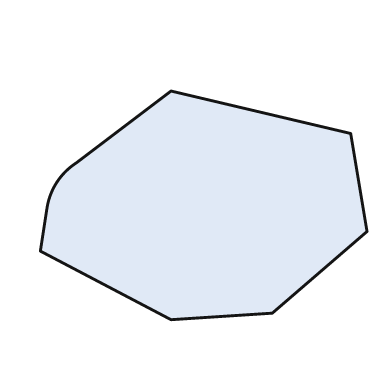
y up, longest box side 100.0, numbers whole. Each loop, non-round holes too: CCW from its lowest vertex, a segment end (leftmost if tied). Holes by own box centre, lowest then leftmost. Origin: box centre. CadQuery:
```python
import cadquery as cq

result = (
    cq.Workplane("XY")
    .moveTo(-10.0, -35.0)
    .lineTo(21.0, -33.0)
    .lineTo(50.0, -8.0)
    .lineTo(45.0, 22.0)
    .lineTo(-10.0, 35.0)
    .lineTo(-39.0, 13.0)
    .threePointArc((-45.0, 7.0), (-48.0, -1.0))
    .lineTo(-50.0, -14.0)
    .close()
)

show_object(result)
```